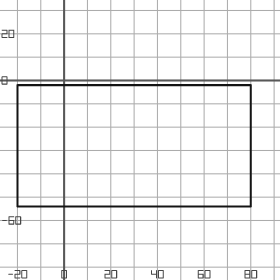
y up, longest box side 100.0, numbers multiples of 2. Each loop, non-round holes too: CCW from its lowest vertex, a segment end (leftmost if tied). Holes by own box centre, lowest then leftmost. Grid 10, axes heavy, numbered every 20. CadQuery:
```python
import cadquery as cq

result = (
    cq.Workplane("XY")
    .moveTo(-20.0, -54.0)
    .lineTo(80.0, -54.0)
    .lineTo(80.0, -2.0)
    .lineTo(-20.0, -2.0)
    .close()
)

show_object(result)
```